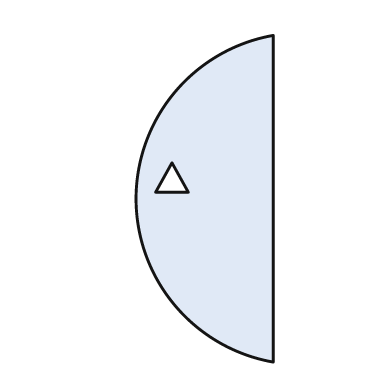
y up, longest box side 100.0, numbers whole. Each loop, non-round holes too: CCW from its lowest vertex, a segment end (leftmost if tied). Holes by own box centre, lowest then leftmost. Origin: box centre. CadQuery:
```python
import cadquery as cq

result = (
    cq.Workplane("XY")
    .moveTo(21.0, -50.0)
    .lineTo(21.0, 50.0)
    .threePointArc((-21.0, 0.0), (21.0, -50.0))
    .close()
    .moveTo(-15.0, 2.0)
    .lineTo(-5.0, 2.0)
    .lineTo(-10.0, 11.0)
    .close()
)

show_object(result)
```